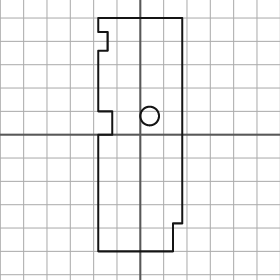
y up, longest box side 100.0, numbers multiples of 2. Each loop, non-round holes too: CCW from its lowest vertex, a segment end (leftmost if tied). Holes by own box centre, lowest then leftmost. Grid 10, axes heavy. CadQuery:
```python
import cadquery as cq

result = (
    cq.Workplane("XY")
    .moveTo(-18.0, -50.0)
    .lineTo(14.0, -50.0)
    .lineTo(14.0, -38.0)
    .lineTo(18.0, -38.0)
    .lineTo(18.0, 50.0)
    .lineTo(-18.0, 50.0)
    .lineTo(-18.0, 44.0)
    .lineTo(-14.0, 44.0)
    .lineTo(-14.0, 36.0)
    .lineTo(-18.0, 36.0)
    .lineTo(-18.0, 10.0)
    .lineTo(-12.0, 10.0)
    .lineTo(-12.0, 0.0)
    .lineTo(-18.0, 0.0)
    .close()
    .moveTo(4.0, 8.0)
    .circle(4.0)
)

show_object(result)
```